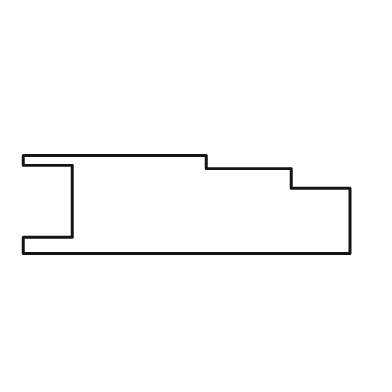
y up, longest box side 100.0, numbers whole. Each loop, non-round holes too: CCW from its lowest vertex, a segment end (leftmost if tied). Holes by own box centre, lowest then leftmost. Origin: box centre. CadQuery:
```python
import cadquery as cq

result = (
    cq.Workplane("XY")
    .moveTo(-50.0, -15.0)
    .lineTo(50.0, -15.0)
    .lineTo(50.0, 5.0)
    .lineTo(32.0, 5.0)
    .lineTo(32.0, 11.0)
    .lineTo(6.0, 11.0)
    .lineTo(6.0, 15.0)
    .lineTo(-50.0, 15.0)
    .lineTo(-50.0, 12.0)
    .lineTo(-35.0, 12.0)
    .lineTo(-35.0, -10.0)
    .lineTo(-50.0, -10.0)
    .close()
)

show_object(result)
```